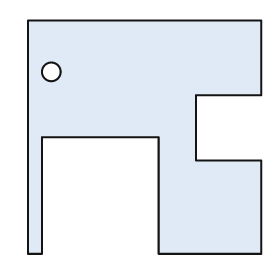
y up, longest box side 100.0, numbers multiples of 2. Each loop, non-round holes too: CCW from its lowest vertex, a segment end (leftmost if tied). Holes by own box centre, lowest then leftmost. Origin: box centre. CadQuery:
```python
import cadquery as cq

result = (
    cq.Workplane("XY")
    .moveTo(-50.0, -50.0)
    .lineTo(-44.0, -50.0)
    .lineTo(-44.0, 0.0)
    .lineTo(6.0, 0.0)
    .lineTo(6.0, -50.0)
    .lineTo(50.0, -50.0)
    .lineTo(50.0, -10.0)
    .lineTo(22.0, -10.0)
    .lineTo(22.0, 18.0)
    .lineTo(50.0, 18.0)
    .lineTo(50.0, 50.0)
    .lineTo(-50.0, 50.0)
    .close()
    .moveTo(-40.0, 28.0)
    .circle(4.0)
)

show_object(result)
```